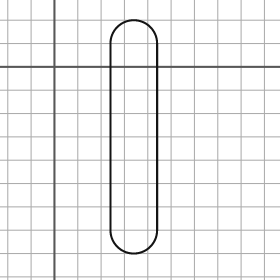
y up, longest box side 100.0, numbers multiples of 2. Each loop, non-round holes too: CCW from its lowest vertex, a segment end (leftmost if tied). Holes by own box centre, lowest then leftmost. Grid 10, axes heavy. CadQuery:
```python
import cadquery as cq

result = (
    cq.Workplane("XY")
    .moveTo(24.0, -70.0)
    .threePointArc((34.0, -80.0), (44.0, -70.0))
    .lineTo(44.0, 10.0)
    .threePointArc((34.0, 20.0), (24.0, 10.0))
    .close()
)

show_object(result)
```